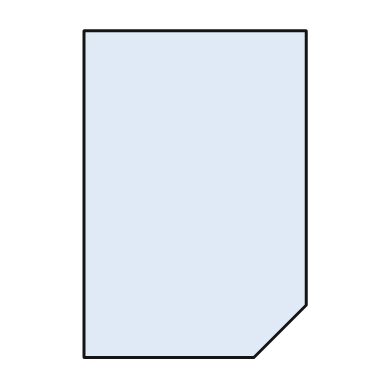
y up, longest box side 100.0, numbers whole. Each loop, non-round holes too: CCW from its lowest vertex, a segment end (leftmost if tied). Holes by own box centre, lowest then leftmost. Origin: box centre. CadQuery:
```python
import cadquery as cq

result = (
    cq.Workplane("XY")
    .moveTo(-34.0, -50.0)
    .lineTo(18.0, -50.0)
    .lineTo(34.0, -34.0)
    .lineTo(34.0, 50.0)
    .lineTo(-34.0, 50.0)
    .close()
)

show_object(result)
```